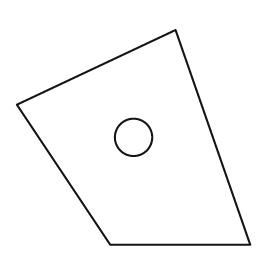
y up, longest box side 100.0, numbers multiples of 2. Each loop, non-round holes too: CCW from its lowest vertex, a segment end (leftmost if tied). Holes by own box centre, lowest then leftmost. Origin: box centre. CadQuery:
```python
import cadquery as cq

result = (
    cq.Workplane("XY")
    .moveTo(-10.0, -46.0)
    .lineTo(50.0, -46.0)
    .lineTo(18.0, 46.0)
    .lineTo(-50.0, 14.0)
    .close()
    .moveTo(0.0, 0.0)
    .circle(8.0)
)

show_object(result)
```